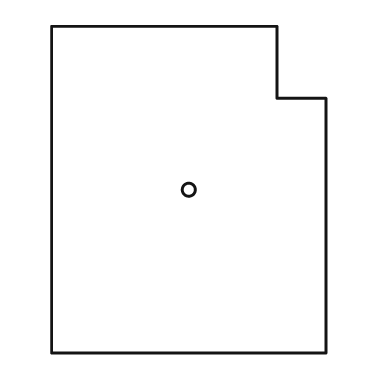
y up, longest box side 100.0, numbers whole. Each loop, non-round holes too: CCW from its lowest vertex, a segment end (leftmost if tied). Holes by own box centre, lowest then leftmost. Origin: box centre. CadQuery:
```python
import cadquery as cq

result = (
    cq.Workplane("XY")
    .moveTo(-42.0, -50.0)
    .lineTo(42.0, -50.0)
    .lineTo(42.0, 28.0)
    .lineTo(27.0, 28.0)
    .lineTo(27.0, 50.0)
    .lineTo(-42.0, 50.0)
    .close()
    .moveTo(0.0, 0.0)
    .circle(2.0)
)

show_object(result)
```